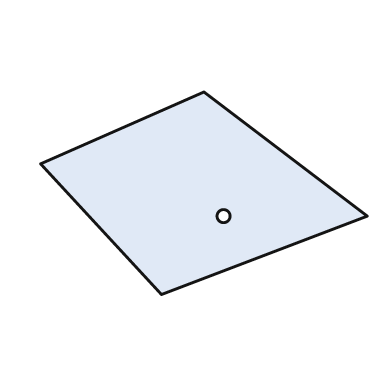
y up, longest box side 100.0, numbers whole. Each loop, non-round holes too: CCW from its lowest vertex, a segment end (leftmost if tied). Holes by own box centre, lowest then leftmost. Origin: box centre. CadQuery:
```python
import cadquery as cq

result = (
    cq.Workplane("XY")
    .moveTo(-13.0, -31.0)
    .lineTo(50.0, -7.0)
    .lineTo(0.0, 31.0)
    .lineTo(-50.0, 9.0)
    .close()
    .moveTo(6.0, -7.0)
    .circle(2.0)
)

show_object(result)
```